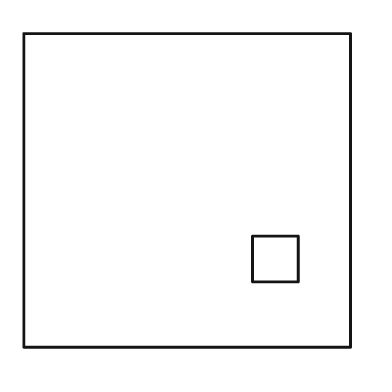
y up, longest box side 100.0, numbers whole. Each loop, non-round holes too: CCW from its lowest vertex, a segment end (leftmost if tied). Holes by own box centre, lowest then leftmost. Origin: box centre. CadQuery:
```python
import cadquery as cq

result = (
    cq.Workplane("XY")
    .moveTo(-50.0, -48.0)
    .lineTo(50.0, -48.0)
    .lineTo(50.0, 48.0)
    .lineTo(-50.0, 48.0)
    .close()
    .moveTo(20.0, -28.0)
    .lineTo(34.0, -28.0)
    .lineTo(34.0, -14.0)
    .lineTo(20.0, -14.0)
    .close()
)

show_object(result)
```